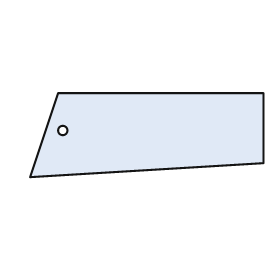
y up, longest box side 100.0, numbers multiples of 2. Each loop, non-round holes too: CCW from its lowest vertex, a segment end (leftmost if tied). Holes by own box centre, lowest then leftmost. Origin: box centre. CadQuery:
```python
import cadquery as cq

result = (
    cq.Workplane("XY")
    .moveTo(-50.0, -18.0)
    .lineTo(50.0, -12.0)
    .lineTo(50.0, 18.0)
    .lineTo(-38.0, 18.0)
    .close()
    .moveTo(-36.0, 2.0)
    .circle(2.0)
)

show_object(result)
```